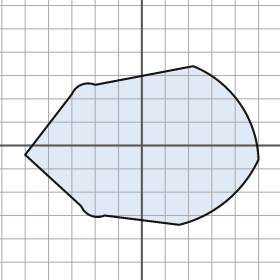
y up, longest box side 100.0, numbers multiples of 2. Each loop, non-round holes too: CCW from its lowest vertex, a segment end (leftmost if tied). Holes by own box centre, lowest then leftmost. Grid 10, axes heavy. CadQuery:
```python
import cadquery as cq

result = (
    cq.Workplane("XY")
    .moveTo(16.0, -34.0)
    .threePointArc((36.0, -24.0), (50.0, -6.0))
    .threePointArc((42.0, 18.0), (22.0, 34.0))
    .lineTo(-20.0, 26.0)
    .threePointArc((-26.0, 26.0), (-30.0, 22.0))
    .lineTo(-50.0, -4.0)
    .lineTo(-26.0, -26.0)
    .threePointArc((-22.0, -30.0), (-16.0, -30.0))
    .close()
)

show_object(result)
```